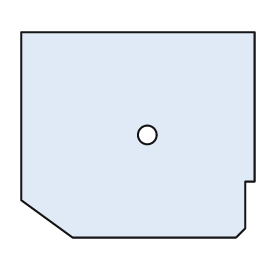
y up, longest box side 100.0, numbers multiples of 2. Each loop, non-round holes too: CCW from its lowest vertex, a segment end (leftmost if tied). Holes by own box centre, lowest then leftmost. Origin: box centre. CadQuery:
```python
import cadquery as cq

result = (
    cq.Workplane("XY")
    .moveTo(-28.0, -44.0)
    .lineTo(42.0, -44.0)
    .lineTo(46.0, -40.0)
    .lineTo(46.0, -20.0)
    .lineTo(50.0, -20.0)
    .lineTo(50.0, 44.0)
    .lineTo(-50.0, 44.0)
    .lineTo(-50.0, -28.0)
    .close()
    .moveTo(4.0, 0.0)
    .circle(4.0)
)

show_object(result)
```